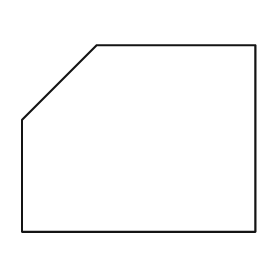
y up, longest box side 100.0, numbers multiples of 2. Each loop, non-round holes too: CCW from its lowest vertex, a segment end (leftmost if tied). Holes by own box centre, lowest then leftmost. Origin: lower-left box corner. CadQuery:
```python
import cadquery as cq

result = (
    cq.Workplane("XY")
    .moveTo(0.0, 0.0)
    .lineTo(100.0, 0.0)
    .lineTo(100.0, 80.0)
    .lineTo(32.0, 80.0)
    .lineTo(0.0, 48.0)
    .close()
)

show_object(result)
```